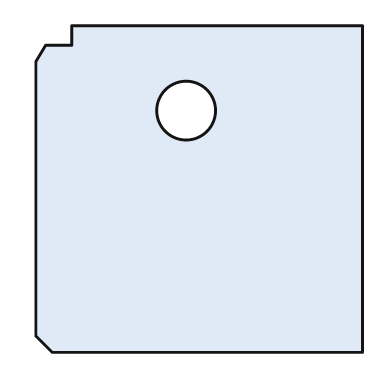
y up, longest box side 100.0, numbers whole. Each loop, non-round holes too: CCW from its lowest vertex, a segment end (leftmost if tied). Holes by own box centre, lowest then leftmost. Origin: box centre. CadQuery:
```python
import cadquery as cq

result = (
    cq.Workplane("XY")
    .moveTo(-45.0, -50.0)
    .lineTo(50.0, -50.0)
    .lineTo(50.0, 50.0)
    .lineTo(-39.0, 50.0)
    .lineTo(-39.0, 44.0)
    .lineTo(-47.0, 44.0)
    .lineTo(-50.0, 39.0)
    .lineTo(-50.0, -45.0)
    .close()
    .moveTo(-4.0, 24.0)
    .circle(9.0)
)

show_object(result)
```